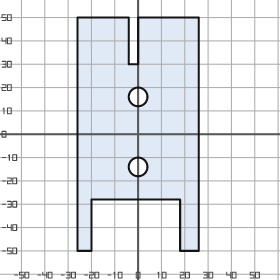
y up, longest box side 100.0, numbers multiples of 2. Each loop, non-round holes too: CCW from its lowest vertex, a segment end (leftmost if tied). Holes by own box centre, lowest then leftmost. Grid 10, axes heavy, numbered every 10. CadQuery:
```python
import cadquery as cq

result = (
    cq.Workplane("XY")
    .moveTo(-26.0, -50.0)
    .lineTo(-20.0, -50.0)
    .lineTo(-20.0, -28.0)
    .lineTo(18.0, -28.0)
    .lineTo(18.0, -50.0)
    .lineTo(26.0, -50.0)
    .lineTo(26.0, 50.0)
    .lineTo(0.0, 50.0)
    .lineTo(0.0, 30.0)
    .lineTo(-4.0, 30.0)
    .lineTo(-4.0, 50.0)
    .lineTo(-26.0, 50.0)
    .close()
    .moveTo(0.0, -14.0)
    .circle(4.0)
    .moveTo(0.0, 16.0)
    .circle(4.0)
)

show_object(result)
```